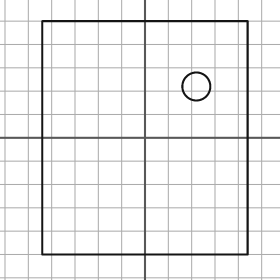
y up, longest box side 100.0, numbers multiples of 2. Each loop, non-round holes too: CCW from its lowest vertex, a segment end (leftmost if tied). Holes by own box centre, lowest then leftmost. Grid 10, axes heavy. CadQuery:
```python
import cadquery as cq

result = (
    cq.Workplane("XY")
    .moveTo(-44.0, -50.0)
    .lineTo(44.0, -50.0)
    .lineTo(44.0, 50.0)
    .lineTo(-44.0, 50.0)
    .close()
    .moveTo(22.0, 22.0)
    .circle(6.0)
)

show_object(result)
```